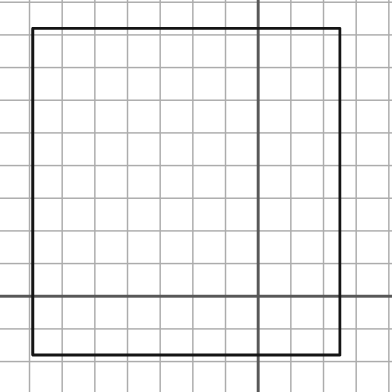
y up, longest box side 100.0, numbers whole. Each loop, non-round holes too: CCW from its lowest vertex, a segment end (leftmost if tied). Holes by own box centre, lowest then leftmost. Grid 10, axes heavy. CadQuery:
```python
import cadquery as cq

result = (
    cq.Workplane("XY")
    .moveTo(-69.0, -18.0)
    .lineTo(25.0, -18.0)
    .lineTo(25.0, 82.0)
    .lineTo(-69.0, 82.0)
    .close()
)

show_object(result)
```